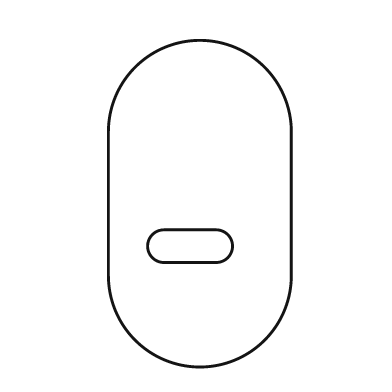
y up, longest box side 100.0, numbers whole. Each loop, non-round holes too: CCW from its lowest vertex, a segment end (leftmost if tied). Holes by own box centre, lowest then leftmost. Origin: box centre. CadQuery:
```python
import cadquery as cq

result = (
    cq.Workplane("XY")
    .moveTo(-28.0, -22.0)
    .threePointArc((0.0, -50.0), (28.0, -22.0))
    .lineTo(28.0, 22.0)
    .threePointArc((0.0, 50.0), (-28.0, 22.0))
    .close()
    .moveTo(-11.0, -18.0)
    .lineTo(5.0, -18.0)
    .threePointArc((10.0, -13.0), (5.0, -8.0))
    .lineTo(-11.0, -8.0)
    .threePointArc((-16.0, -13.0), (-11.0, -18.0))
    .close()
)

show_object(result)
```